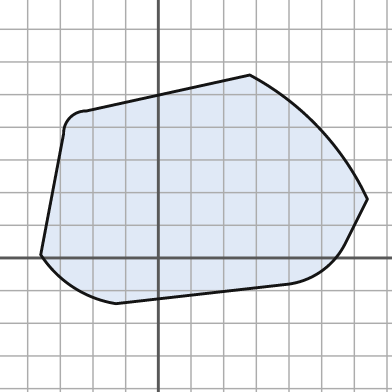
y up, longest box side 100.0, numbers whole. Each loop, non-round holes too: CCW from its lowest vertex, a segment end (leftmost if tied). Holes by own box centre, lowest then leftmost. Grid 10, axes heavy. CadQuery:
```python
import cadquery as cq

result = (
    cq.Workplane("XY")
    .moveTo(-13.0, -14.0)
    .lineTo(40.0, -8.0)
    .threePointArc((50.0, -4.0), (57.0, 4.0))
    .lineTo(64.0, 18.0)
    .threePointArc((49.0, 40.0), (28.0, 56.0))
    .lineTo(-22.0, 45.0)
    .threePointArc((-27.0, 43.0), (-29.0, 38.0))
    .lineTo(-36.0, 1.0)
    .threePointArc((-26.0, -9.0), (-13.0, -14.0))
    .close()
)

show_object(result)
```